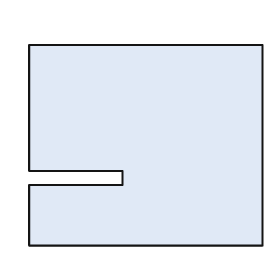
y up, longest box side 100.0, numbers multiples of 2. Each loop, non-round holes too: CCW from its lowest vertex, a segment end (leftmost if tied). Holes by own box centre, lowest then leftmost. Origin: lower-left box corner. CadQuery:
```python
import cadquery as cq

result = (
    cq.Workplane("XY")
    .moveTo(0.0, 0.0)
    .lineTo(100.0, 0.0)
    .lineTo(100.0, 86.0)
    .lineTo(0.0, 86.0)
    .lineTo(0.0, 32.0)
    .lineTo(40.0, 32.0)
    .lineTo(40.0, 26.0)
    .lineTo(0.0, 26.0)
    .close()
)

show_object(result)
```